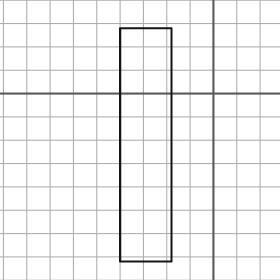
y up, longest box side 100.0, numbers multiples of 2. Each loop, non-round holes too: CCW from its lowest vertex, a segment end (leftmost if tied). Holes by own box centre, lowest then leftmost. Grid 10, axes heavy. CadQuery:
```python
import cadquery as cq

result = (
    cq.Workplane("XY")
    .moveTo(-40.0, -72.0)
    .lineTo(-18.0, -72.0)
    .lineTo(-18.0, 28.0)
    .lineTo(-40.0, 28.0)
    .close()
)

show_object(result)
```